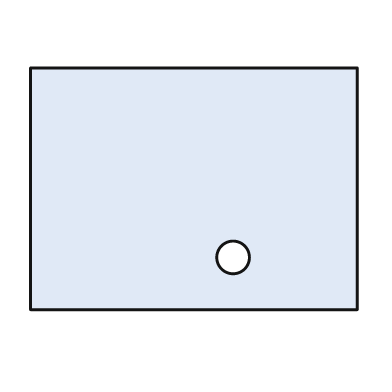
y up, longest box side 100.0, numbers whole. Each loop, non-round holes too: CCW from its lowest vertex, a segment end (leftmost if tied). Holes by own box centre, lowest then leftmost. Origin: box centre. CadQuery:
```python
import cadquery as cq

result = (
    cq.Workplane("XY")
    .moveTo(-50.0, -37.0)
    .lineTo(50.0, -37.0)
    .lineTo(50.0, 37.0)
    .lineTo(-50.0, 37.0)
    .close()
    .moveTo(12.0, -21.0)
    .circle(5.0)
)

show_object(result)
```